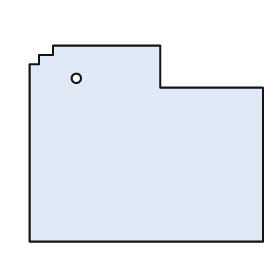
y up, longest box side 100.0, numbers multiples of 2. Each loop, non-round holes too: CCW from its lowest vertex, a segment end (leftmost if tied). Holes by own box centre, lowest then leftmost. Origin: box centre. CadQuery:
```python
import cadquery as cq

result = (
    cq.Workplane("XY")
    .moveTo(-50.0, -42.0)
    .lineTo(50.0, -42.0)
    .lineTo(50.0, 24.0)
    .lineTo(6.0, 24.0)
    .lineTo(6.0, 42.0)
    .lineTo(-40.0, 42.0)
    .lineTo(-40.0, 38.0)
    .lineTo(-46.0, 38.0)
    .lineTo(-46.0, 34.0)
    .lineTo(-50.0, 34.0)
    .close()
    .moveTo(-30.0, 28.0)
    .circle(2.0)
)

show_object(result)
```